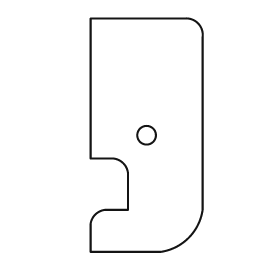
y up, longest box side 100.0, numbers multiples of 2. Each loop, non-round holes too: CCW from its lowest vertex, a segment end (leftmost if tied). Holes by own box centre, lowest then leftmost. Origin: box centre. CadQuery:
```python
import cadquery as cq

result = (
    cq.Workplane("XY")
    .moveTo(-24.0, -50.0)
    .lineTo(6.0, -50.0)
    .threePointArc((18.0, -44.0), (24.0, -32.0))
    .lineTo(24.0, 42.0)
    .threePointArc((22.0, 48.0), (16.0, 50.0))
    .lineTo(-24.0, 50.0)
    .lineTo(-24.0, -10.0)
    .lineTo(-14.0, -10.0)
    .threePointArc((-10.0, -12.0), (-8.0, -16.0))
    .lineTo(-8.0, -32.0)
    .lineTo(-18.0, -32.0)
    .threePointArc((-22.0, -34.0), (-24.0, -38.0))
    .close()
    .moveTo(0.0, 0.0)
    .circle(4.0)
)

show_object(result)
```